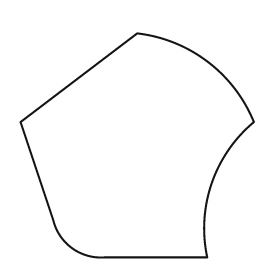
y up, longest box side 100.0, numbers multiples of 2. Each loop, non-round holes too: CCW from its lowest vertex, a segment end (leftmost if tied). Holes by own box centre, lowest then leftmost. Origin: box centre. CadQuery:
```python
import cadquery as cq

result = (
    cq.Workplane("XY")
    .moveTo(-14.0, -48.0)
    .lineTo(30.0, -48.0)
    .threePointArc((32.0, -16.0), (50.0, 10.0))
    .threePointArc((30.0, 36.0), (0.0, 48.0))
    .lineTo(-50.0, 10.0)
    .lineTo(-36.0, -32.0)
    .threePointArc((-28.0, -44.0), (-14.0, -48.0))
    .close()
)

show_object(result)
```